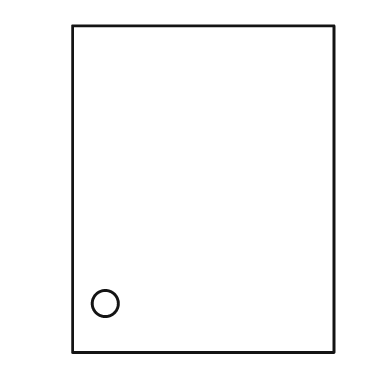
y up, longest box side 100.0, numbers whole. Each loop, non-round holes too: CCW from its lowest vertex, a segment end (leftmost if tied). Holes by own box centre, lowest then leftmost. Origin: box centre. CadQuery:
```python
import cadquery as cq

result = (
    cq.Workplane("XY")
    .moveTo(-40.0, -50.0)
    .lineTo(40.0, -50.0)
    .lineTo(40.0, 50.0)
    .lineTo(-40.0, 50.0)
    .close()
    .moveTo(-30.0, -35.0)
    .circle(4.0)
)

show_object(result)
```